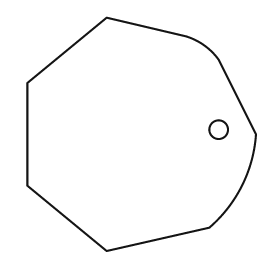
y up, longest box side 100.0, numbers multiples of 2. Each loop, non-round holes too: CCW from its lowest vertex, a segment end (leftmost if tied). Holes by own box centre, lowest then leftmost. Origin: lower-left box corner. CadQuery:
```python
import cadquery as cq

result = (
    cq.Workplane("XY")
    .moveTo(34.0, 0.0)
    .lineTo(78.0, 10.0)
    .threePointArc((92.0, 28.0), (98.0, 50.0))
    .lineTo(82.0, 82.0)
    .threePointArc((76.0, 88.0), (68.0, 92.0))
    .lineTo(34.0, 100.0)
    .lineTo(0.0, 72.0)
    .lineTo(0.0, 28.0)
    .close()
    .moveTo(82.0, 52.0)
    .circle(4.0)
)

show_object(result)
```